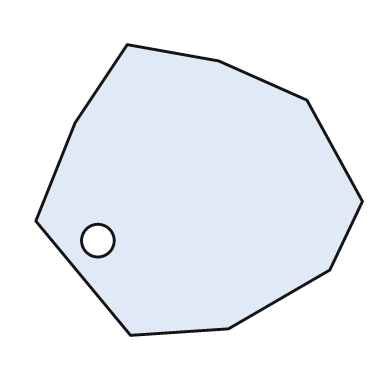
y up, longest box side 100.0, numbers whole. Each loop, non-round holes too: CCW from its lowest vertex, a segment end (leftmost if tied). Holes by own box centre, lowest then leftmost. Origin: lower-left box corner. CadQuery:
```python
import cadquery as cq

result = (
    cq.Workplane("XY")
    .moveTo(29.0, 0.0)
    .lineTo(59.0, 2.0)
    .lineTo(90.0, 20.0)
    .lineTo(100.0, 41.0)
    .lineTo(83.0, 72.0)
    .lineTo(56.0, 84.0)
    .lineTo(28.0, 89.0)
    .lineTo(12.0, 65.0)
    .lineTo(0.0, 35.0)
    .close()
    .moveTo(19.0, 29.0)
    .circle(5.0)
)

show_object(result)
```